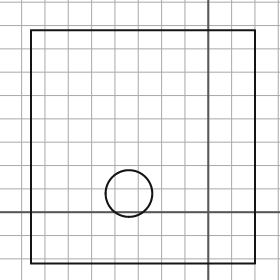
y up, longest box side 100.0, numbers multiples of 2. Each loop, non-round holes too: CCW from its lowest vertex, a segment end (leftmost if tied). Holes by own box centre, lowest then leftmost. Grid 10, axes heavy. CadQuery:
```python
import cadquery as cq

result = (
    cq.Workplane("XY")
    .moveTo(-76.0, -22.0)
    .lineTo(20.0, -22.0)
    .lineTo(20.0, 78.0)
    .lineTo(-76.0, 78.0)
    .close()
    .moveTo(-34.0, 8.0)
    .circle(10.0)
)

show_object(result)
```